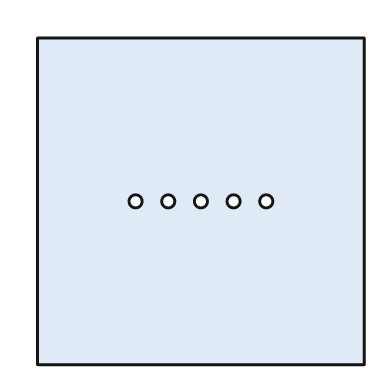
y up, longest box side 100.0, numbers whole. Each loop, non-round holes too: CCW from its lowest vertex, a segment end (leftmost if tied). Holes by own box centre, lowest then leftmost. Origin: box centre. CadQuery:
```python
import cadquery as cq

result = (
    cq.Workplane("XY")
    .moveTo(-50.0, -50.0)
    .lineTo(50.0, -50.0)
    .lineTo(50.0, 50.0)
    .lineTo(-50.0, 50.0)
    .close()
    .moveTo(-20.0, 0.0)
    .circle(2.0)
    .moveTo(-10.0, 0.0)
    .circle(2.0)
    .moveTo(0.0, 0.0)
    .circle(2.0)
    .moveTo(10.0, 0.0)
    .circle(2.0)
    .moveTo(20.0, 0.0)
    .circle(2.0)
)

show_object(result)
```